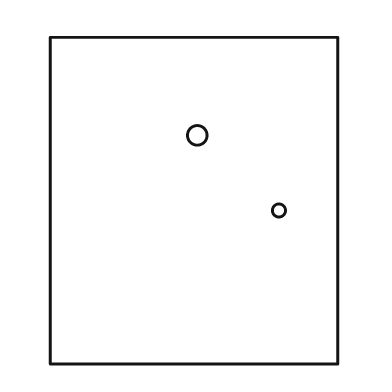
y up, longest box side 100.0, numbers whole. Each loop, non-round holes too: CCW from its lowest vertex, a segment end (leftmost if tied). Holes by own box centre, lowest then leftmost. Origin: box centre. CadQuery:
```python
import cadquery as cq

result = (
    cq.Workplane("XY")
    .moveTo(-44.0, -50.0)
    .lineTo(44.0, -50.0)
    .lineTo(44.0, 50.0)
    .lineTo(-44.0, 50.0)
    .close()
    .moveTo(26.0, -3.0)
    .circle(2.0)
    .moveTo(1.0, 20.0)
    .circle(3.0)
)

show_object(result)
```